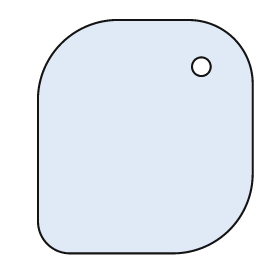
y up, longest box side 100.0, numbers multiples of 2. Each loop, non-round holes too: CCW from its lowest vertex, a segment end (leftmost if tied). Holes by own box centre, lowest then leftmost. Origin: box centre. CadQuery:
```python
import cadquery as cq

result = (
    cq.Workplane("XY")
    .moveTo(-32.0, -50.0)
    .lineTo(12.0, -50.0)
    .threePointArc((36.0, -40.0), (46.0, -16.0))
    .lineTo(46.0, 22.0)
    .threePointArc((38.0, 42.0), (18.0, 50.0))
    .lineTo(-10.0, 50.0)
    .threePointArc((-36.0, 40.0), (-46.0, 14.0))
    .lineTo(-46.0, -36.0)
    .threePointArc((-42.0, -46.0), (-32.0, -50.0))
    .close()
    .moveTo(24.0, 30.0)
    .circle(4.0)
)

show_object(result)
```